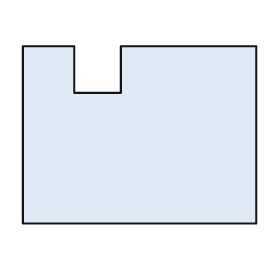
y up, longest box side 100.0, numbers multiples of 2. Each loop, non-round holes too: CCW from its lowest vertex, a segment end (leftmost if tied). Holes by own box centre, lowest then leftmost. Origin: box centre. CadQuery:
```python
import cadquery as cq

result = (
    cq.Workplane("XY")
    .moveTo(-50.0, -38.0)
    .lineTo(50.0, -38.0)
    .lineTo(50.0, 38.0)
    .lineTo(-8.0, 38.0)
    .lineTo(-8.0, 18.0)
    .lineTo(-28.0, 18.0)
    .lineTo(-28.0, 38.0)
    .lineTo(-50.0, 38.0)
    .close()
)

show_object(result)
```